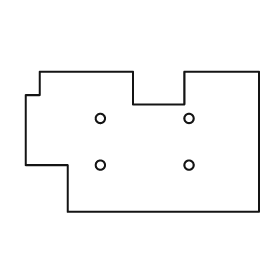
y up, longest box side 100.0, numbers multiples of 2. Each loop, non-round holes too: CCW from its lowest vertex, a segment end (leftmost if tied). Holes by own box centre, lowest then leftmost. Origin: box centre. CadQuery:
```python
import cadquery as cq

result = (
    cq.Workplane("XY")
    .moveTo(-32.0, -30.0)
    .lineTo(50.0, -30.0)
    .lineTo(50.0, 30.0)
    .lineTo(18.0, 30.0)
    .lineTo(18.0, 16.0)
    .lineTo(-4.0, 16.0)
    .lineTo(-4.0, 30.0)
    .lineTo(-44.0, 30.0)
    .lineTo(-44.0, 20.0)
    .lineTo(-50.0, 20.0)
    .lineTo(-50.0, -10.0)
    .lineTo(-32.0, -10.0)
    .close()
    .moveTo(-18.0, -10.0)
    .circle(2.0)
    .moveTo(20.0, -10.0)
    .circle(2.0)
    .moveTo(-18.0, 10.0)
    .circle(2.0)
    .moveTo(20.0, 10.0)
    .circle(2.0)
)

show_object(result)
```